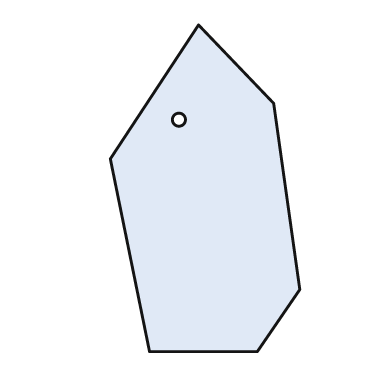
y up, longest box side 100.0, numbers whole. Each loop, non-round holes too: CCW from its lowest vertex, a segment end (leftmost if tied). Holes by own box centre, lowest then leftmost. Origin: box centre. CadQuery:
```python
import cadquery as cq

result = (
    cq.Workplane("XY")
    .moveTo(-17.0, -50.0)
    .lineTo(16.0, -50.0)
    .lineTo(29.0, -31.0)
    .lineTo(21.0, 26.0)
    .lineTo(-2.0, 50.0)
    .lineTo(-29.0, 9.0)
    .close()
    .moveTo(-8.0, 21.0)
    .circle(2.0)
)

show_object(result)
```